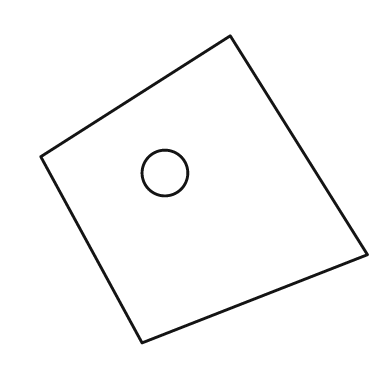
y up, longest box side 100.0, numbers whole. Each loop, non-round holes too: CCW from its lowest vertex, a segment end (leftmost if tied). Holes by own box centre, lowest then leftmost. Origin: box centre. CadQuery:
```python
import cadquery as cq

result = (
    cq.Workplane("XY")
    .moveTo(-19.0, -47.0)
    .lineTo(50.0, -20.0)
    .lineTo(8.0, 47.0)
    .lineTo(-50.0, 10.0)
    .close()
    .moveTo(-12.0, 5.0)
    .circle(7.0)
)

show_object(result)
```